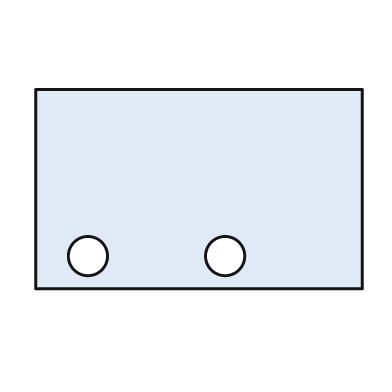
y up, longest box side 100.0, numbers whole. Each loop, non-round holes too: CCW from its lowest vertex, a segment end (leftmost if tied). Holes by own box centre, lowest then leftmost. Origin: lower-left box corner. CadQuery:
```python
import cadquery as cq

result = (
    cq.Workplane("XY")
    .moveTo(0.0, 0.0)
    .lineTo(100.0, 0.0)
    .lineTo(100.0, 61.0)
    .lineTo(0.0, 61.0)
    .close()
    .moveTo(16.0, 10.0)
    .circle(6.0)
    .moveTo(58.0, 10.0)
    .circle(6.0)
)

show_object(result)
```